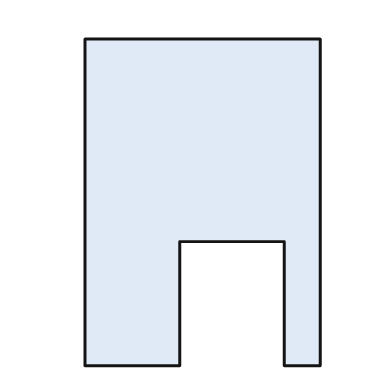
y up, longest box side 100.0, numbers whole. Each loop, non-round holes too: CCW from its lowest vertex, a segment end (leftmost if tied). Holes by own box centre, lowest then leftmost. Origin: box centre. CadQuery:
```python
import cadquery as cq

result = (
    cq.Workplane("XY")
    .moveTo(-36.0, -50.0)
    .lineTo(-7.0, -50.0)
    .lineTo(-7.0, -12.0)
    .lineTo(25.0, -12.0)
    .lineTo(25.0, -50.0)
    .lineTo(36.0, -50.0)
    .lineTo(36.0, 50.0)
    .lineTo(-36.0, 50.0)
    .close()
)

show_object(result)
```